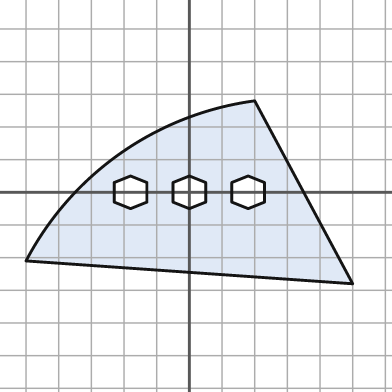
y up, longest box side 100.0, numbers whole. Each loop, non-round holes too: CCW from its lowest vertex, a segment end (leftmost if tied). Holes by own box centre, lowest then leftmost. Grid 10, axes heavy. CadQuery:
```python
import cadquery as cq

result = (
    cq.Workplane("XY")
    .moveTo(50.0, -28.0)
    .lineTo(20.0, 28.0)
    .threePointArc((-21.0, 12.0), (-50.0, -21.0))
    .close()
    .moveTo(-18.0, -5.0)
    .lineTo(-13.0, -3.0)
    .lineTo(-13.0, 3.0)
    .lineTo(-18.0, 5.0)
    .lineTo(-23.0, 3.0)
    .lineTo(-23.0, -3.0)
    .close()
    .moveTo(0.0, -5.0)
    .lineTo(5.0, -3.0)
    .lineTo(5.0, 3.0)
    .lineTo(0.0, 5.0)
    .lineTo(-5.0, 3.0)
    .lineTo(-5.0, -3.0)
    .close()
    .moveTo(18.0, -5.0)
    .lineTo(23.0, -3.0)
    .lineTo(23.0, 3.0)
    .lineTo(18.0, 5.0)
    .lineTo(13.0, 3.0)
    .lineTo(13.0, -3.0)
    .close()
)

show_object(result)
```